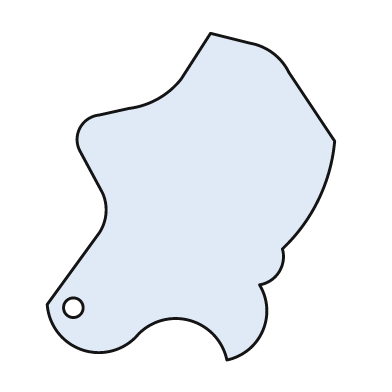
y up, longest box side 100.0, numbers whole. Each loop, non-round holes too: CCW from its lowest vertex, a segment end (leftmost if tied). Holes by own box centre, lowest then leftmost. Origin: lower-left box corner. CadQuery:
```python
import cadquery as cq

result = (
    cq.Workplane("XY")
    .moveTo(55.0, 0.0)
    .threePointArc((66.0, 9.0), (65.0, 23.0))
    .threePointArc((71.0, 27.0), (72.0, 34.0))
    .threePointArc((83.0, 49.0), (88.0, 67.0))
    .lineTo(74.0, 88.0)
    .threePointArc((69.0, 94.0), (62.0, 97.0))
    .lineTo(50.0, 100.0)
    .lineTo(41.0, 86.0)
    .threePointArc((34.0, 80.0), (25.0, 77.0))
    .lineTo(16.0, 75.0)
    .threePointArc((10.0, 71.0), (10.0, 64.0))
    .lineTo(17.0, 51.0)
    .threePointArc((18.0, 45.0), (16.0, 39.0))
    .lineTo(0.0, 17.0)
    .threePointArc((11.0, 3.0), (28.0, 8.0))
    .threePointArc((44.0, 12.0), (55.0, 0.0))
    .close()
    .moveTo(8.0, 16.0)
    .circle(3.0)
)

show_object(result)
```